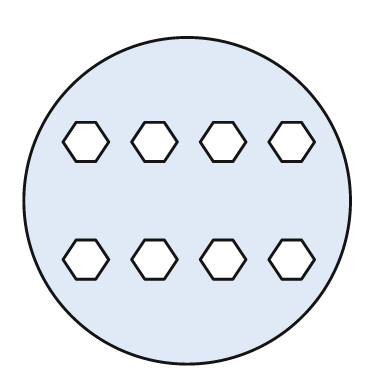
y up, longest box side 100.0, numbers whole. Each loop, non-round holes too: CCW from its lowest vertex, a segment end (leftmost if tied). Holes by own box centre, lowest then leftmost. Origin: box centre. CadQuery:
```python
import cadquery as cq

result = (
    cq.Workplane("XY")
    .moveTo(0.0, 0.0)
    .circle(50.0)
    .moveTo(-34.0, -24.0)
    .lineTo(-28.0, -24.0)
    .lineTo(-24.0, -18.0)
    .lineTo(-28.0, -12.0)
    .lineTo(-34.0, -12.0)
    .lineTo(-38.0, -18.0)
    .close()
    .moveTo(-13.0, -24.0)
    .lineTo(-7.0, -24.0)
    .lineTo(-3.0, -18.0)
    .lineTo(-7.0, -12.0)
    .lineTo(-13.0, -12.0)
    .lineTo(-17.0, -18.0)
    .close()
    .moveTo(8.0, -24.0)
    .lineTo(14.0, -24.0)
    .lineTo(18.0, -18.0)
    .lineTo(14.0, -12.0)
    .lineTo(8.0, -12.0)
    .lineTo(4.0, -18.0)
    .close()
    .moveTo(29.0, -24.0)
    .lineTo(35.0, -24.0)
    .lineTo(39.0, -18.0)
    .lineTo(35.0, -12.0)
    .lineTo(29.0, -12.0)
    .lineTo(25.0, -18.0)
    .close()
    .moveTo(-34.0, 12.0)
    .lineTo(-28.0, 12.0)
    .lineTo(-24.0, 18.0)
    .lineTo(-28.0, 24.0)
    .lineTo(-34.0, 24.0)
    .lineTo(-38.0, 18.0)
    .close()
    .moveTo(-13.0, 12.0)
    .lineTo(-7.0, 12.0)
    .lineTo(-3.0, 18.0)
    .lineTo(-7.0, 24.0)
    .lineTo(-13.0, 24.0)
    .lineTo(-17.0, 18.0)
    .close()
    .moveTo(8.0, 12.0)
    .lineTo(14.0, 12.0)
    .lineTo(18.0, 18.0)
    .lineTo(14.0, 24.0)
    .lineTo(8.0, 24.0)
    .lineTo(4.0, 18.0)
    .close()
    .moveTo(29.0, 12.0)
    .lineTo(35.0, 12.0)
    .lineTo(39.0, 18.0)
    .lineTo(35.0, 24.0)
    .lineTo(29.0, 24.0)
    .lineTo(25.0, 18.0)
    .close()
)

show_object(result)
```